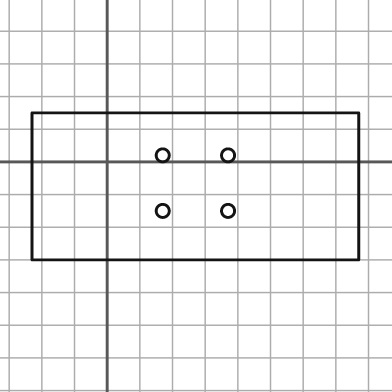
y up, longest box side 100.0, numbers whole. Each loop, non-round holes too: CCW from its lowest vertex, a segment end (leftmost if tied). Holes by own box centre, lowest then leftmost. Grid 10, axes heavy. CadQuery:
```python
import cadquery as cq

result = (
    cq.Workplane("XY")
    .moveTo(-23.0, -30.0)
    .lineTo(77.0, -30.0)
    .lineTo(77.0, 15.0)
    .lineTo(-23.0, 15.0)
    .close()
    .moveTo(17.0, -15.0)
    .circle(2.0)
    .moveTo(37.0, -15.0)
    .circle(2.0)
    .moveTo(17.0, 2.0)
    .circle(2.0)
    .moveTo(37.0, 2.0)
    .circle(2.0)
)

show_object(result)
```